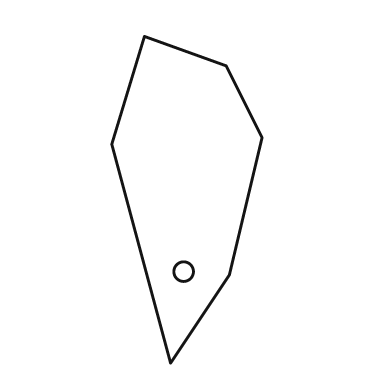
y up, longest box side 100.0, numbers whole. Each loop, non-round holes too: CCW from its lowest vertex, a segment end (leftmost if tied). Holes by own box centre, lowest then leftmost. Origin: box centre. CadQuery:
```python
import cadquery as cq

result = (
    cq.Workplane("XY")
    .moveTo(-5.0, -50.0)
    .lineTo(13.0, -23.0)
    .lineTo(23.0, 19.0)
    .lineTo(12.0, 41.0)
    .lineTo(-13.0, 50.0)
    .lineTo(-23.0, 17.0)
    .close()
    .moveTo(-1.0, -22.0)
    .circle(3.0)
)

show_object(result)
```